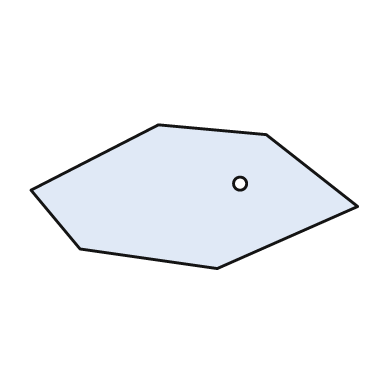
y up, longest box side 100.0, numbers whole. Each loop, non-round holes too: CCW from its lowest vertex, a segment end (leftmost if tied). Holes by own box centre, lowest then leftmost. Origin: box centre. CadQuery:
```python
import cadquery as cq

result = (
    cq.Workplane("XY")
    .moveTo(7.0, -22.0)
    .lineTo(50.0, -3.0)
    .lineTo(22.0, 19.0)
    .lineTo(-11.0, 22.0)
    .lineTo(-50.0, 2.0)
    .lineTo(-35.0, -16.0)
    .close()
    .moveTo(14.0, 4.0)
    .circle(2.0)
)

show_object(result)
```